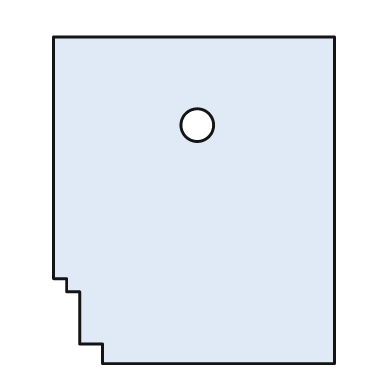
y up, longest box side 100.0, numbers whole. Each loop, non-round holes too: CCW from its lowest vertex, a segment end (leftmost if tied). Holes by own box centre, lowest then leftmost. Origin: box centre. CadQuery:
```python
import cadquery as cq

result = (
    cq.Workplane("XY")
    .moveTo(-28.0, -50.0)
    .lineTo(43.0, -50.0)
    .lineTo(43.0, 50.0)
    .lineTo(-43.0, 50.0)
    .lineTo(-43.0, -24.0)
    .lineTo(-39.0, -24.0)
    .lineTo(-39.0, -28.0)
    .lineTo(-35.0, -28.0)
    .lineTo(-35.0, -44.0)
    .lineTo(-28.0, -44.0)
    .close()
    .moveTo(1.0, 23.0)
    .circle(5.0)
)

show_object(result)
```